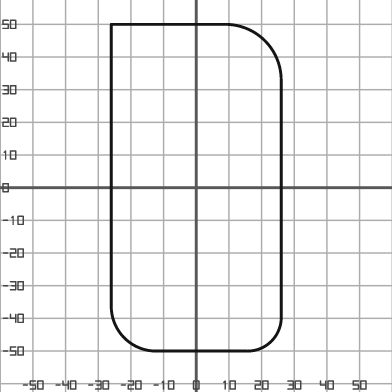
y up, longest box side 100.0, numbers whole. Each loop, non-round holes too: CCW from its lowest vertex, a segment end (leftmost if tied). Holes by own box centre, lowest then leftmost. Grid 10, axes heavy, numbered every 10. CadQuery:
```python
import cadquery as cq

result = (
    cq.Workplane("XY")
    .moveTo(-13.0, -50.0)
    .lineTo(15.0, -50.0)
    .threePointArc((23.0, -47.0), (26.0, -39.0))
    .lineTo(26.0, 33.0)
    .threePointArc((21.0, 45.0), (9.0, 50.0))
    .lineTo(-26.0, 50.0)
    .lineTo(-26.0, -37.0)
    .threePointArc((-22.0, -46.0), (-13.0, -50.0))
    .close()
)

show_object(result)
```